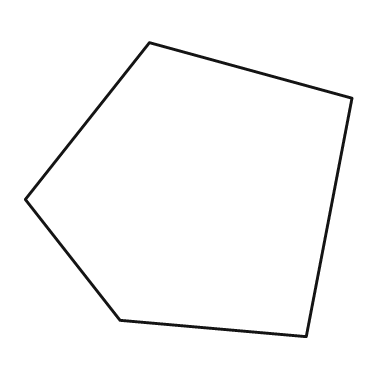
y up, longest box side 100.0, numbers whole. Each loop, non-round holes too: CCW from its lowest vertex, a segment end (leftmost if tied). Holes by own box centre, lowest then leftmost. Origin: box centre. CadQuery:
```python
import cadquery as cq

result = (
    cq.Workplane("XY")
    .moveTo(36.0, -45.0)
    .lineTo(50.0, 28.0)
    .lineTo(-12.0, 45.0)
    .lineTo(-50.0, -3.0)
    .lineTo(-21.0, -40.0)
    .close()
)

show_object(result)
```